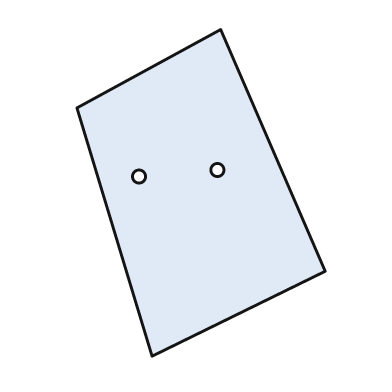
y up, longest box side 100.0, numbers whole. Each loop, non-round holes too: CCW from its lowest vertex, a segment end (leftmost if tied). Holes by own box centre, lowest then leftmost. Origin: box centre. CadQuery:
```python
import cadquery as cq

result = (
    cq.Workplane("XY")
    .moveTo(-15.0, -50.0)
    .lineTo(38.0, -24.0)
    .lineTo(6.0, 50.0)
    .lineTo(-38.0, 26.0)
    .close()
    .moveTo(-19.0, 5.0)
    .circle(2.0)
    .moveTo(5.0, 7.0)
    .circle(2.0)
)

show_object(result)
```